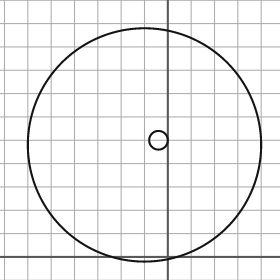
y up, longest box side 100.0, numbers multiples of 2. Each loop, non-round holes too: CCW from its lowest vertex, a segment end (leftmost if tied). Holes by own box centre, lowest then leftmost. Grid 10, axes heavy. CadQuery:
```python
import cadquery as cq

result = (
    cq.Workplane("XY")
    .moveTo(-10.0, 48.0)
    .circle(50.0)
    .moveTo(-4.0, 50.0)
    .circle(4.0)
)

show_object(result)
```